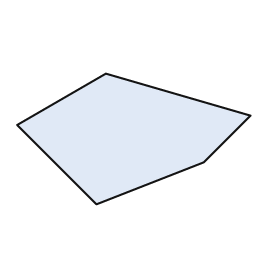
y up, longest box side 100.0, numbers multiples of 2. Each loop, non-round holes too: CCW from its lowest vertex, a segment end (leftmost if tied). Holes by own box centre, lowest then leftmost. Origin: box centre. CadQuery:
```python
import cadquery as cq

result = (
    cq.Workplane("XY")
    .moveTo(-16.0, -28.0)
    .lineTo(30.0, -10.0)
    .lineTo(50.0, 10.0)
    .lineTo(-12.0, 28.0)
    .lineTo(-50.0, 6.0)
    .close()
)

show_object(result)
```